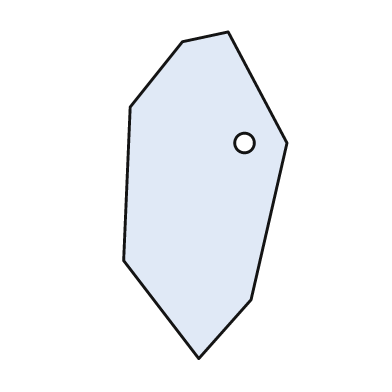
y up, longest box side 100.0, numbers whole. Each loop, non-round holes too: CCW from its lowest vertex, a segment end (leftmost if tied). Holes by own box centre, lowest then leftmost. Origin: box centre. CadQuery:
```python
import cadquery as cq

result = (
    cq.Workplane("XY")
    .moveTo(-2.0, -50.0)
    .lineTo(14.0, -32.0)
    .lineTo(25.0, 16.0)
    .lineTo(7.0, 50.0)
    .lineTo(-7.0, 47.0)
    .lineTo(-23.0, 27.0)
    .lineTo(-25.0, -20.0)
    .close()
    .moveTo(12.0, 16.0)
    .circle(3.0)
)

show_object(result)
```